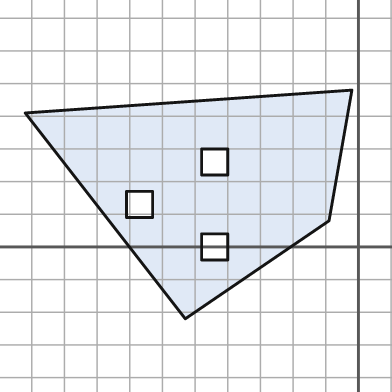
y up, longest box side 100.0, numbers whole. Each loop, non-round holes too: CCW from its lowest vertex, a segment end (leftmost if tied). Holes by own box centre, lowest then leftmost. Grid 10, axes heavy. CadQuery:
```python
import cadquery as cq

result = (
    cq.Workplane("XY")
    .moveTo(-53.0, -22.0)
    .lineTo(-9.0, 8.0)
    .lineTo(-2.0, 48.0)
    .lineTo(-102.0, 41.0)
    .close()
    .moveTo(-48.0, -4.0)
    .lineTo(-40.0, -4.0)
    .lineTo(-40.0, 4.0)
    .lineTo(-48.0, 4.0)
    .close()
    .moveTo(-71.0, 9.0)
    .lineTo(-63.0, 9.0)
    .lineTo(-63.0, 17.0)
    .lineTo(-71.0, 17.0)
    .close()
    .moveTo(-48.0, 22.0)
    .lineTo(-40.0, 22.0)
    .lineTo(-40.0, 30.0)
    .lineTo(-48.0, 30.0)
    .close()
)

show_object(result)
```